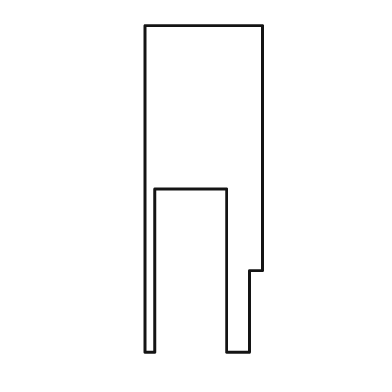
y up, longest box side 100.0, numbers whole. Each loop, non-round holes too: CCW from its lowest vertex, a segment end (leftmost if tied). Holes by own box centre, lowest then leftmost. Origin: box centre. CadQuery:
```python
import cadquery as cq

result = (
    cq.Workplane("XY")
    .moveTo(-18.0, -50.0)
    .lineTo(-15.0, -50.0)
    .lineTo(-15.0, 0.0)
    .lineTo(7.0, 0.0)
    .lineTo(7.0, -50.0)
    .lineTo(14.0, -50.0)
    .lineTo(14.0, -25.0)
    .lineTo(18.0, -25.0)
    .lineTo(18.0, 50.0)
    .lineTo(-18.0, 50.0)
    .close()
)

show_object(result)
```